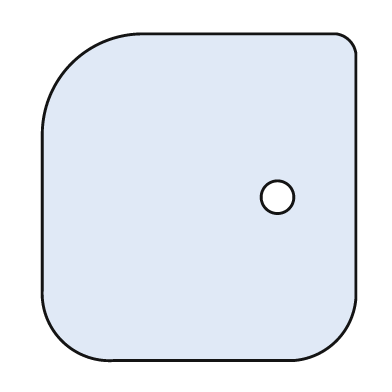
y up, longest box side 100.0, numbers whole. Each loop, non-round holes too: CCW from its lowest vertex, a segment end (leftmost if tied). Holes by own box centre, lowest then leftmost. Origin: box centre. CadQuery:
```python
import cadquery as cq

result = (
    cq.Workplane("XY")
    .moveTo(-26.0, -50.0)
    .lineTo(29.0, -50.0)
    .threePointArc((42.0, -44.0), (48.0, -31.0))
    .lineTo(48.0, 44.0)
    .threePointArc((46.0, 48.0), (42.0, 50.0))
    .lineTo(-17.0, 50.0)
    .threePointArc((-39.0, 41.0), (-48.0, 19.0))
    .lineTo(-48.0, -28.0)
    .threePointArc((-42.0, -44.0), (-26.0, -50.0))
    .close()
    .moveTo(24.0, 0.0)
    .circle(5.0)
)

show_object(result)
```